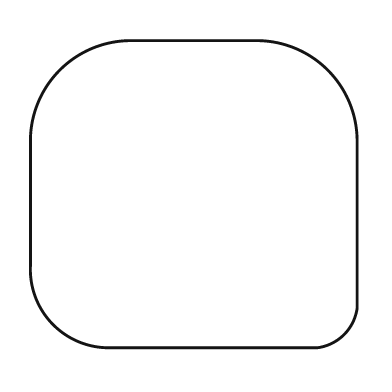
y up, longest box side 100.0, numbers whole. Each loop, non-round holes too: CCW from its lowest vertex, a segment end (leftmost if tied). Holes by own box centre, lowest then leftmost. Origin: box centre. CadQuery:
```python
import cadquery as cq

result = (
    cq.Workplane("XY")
    .moveTo(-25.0, -47.0)
    .lineTo(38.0, -47.0)
    .threePointArc((46.0, -43.0), (50.0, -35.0))
    .lineTo(50.0, 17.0)
    .threePointArc((41.0, 38.0), (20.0, 47.0))
    .lineTo(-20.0, 47.0)
    .threePointArc((-41.0, 38.0), (-50.0, 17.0))
    .lineTo(-50.0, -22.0)
    .threePointArc((-43.0, -40.0), (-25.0, -47.0))
    .close()
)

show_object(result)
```